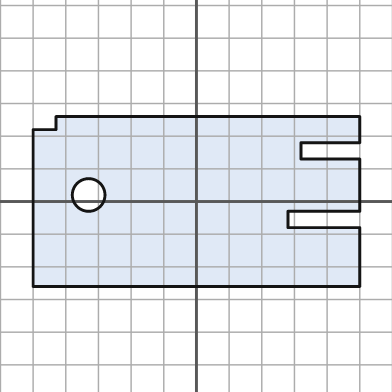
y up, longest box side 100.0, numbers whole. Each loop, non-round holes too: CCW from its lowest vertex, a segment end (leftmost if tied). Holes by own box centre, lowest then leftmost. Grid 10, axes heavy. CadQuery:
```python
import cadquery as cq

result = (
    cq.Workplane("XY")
    .moveTo(-50.0, -26.0)
    .lineTo(50.0, -26.0)
    .lineTo(50.0, -8.0)
    .lineTo(28.0, -8.0)
    .lineTo(28.0, -3.0)
    .lineTo(50.0, -3.0)
    .lineTo(50.0, 13.0)
    .lineTo(32.0, 13.0)
    .lineTo(32.0, 18.0)
    .lineTo(50.0, 18.0)
    .lineTo(50.0, 26.0)
    .lineTo(-43.0, 26.0)
    .lineTo(-43.0, 22.0)
    .lineTo(-50.0, 22.0)
    .close()
    .moveTo(-33.0, 2.0)
    .circle(5.0)
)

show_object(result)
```